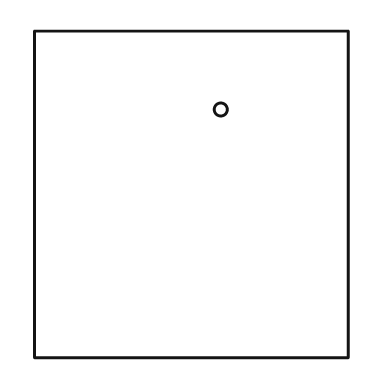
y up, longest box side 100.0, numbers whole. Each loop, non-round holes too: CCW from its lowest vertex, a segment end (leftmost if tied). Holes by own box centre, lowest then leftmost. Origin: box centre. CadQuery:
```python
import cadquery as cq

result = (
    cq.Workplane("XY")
    .moveTo(-48.0, -50.0)
    .lineTo(48.0, -50.0)
    .lineTo(48.0, 50.0)
    .lineTo(-48.0, 50.0)
    .close()
    .moveTo(9.0, 26.0)
    .circle(2.0)
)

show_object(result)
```